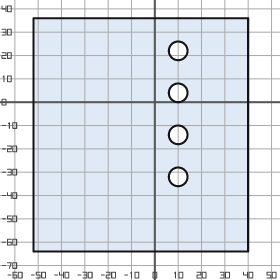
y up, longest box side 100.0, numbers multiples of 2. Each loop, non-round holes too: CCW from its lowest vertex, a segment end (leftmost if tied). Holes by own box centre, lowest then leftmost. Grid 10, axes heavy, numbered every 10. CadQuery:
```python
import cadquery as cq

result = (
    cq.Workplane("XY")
    .moveTo(-52.0, -64.0)
    .lineTo(40.0, -64.0)
    .lineTo(40.0, 36.0)
    .lineTo(-52.0, 36.0)
    .close()
    .moveTo(10.0, -32.0)
    .circle(4.0)
    .moveTo(10.0, -14.0)
    .circle(4.0)
    .moveTo(10.0, 4.0)
    .circle(4.0)
    .moveTo(10.0, 22.0)
    .circle(4.0)
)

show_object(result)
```